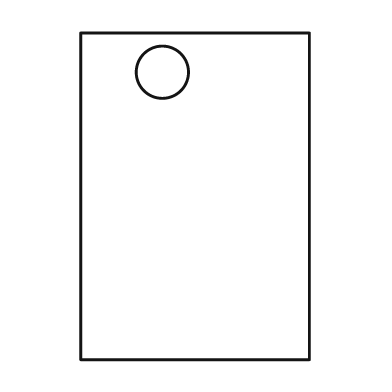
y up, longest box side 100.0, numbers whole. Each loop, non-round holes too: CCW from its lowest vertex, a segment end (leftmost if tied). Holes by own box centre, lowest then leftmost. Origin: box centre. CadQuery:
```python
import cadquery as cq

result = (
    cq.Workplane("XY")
    .moveTo(-35.0, -50.0)
    .lineTo(35.0, -50.0)
    .lineTo(35.0, 50.0)
    .lineTo(-35.0, 50.0)
    .close()
    .moveTo(-10.0, 38.0)
    .circle(8.0)
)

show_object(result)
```